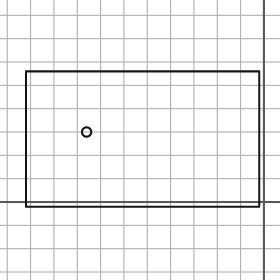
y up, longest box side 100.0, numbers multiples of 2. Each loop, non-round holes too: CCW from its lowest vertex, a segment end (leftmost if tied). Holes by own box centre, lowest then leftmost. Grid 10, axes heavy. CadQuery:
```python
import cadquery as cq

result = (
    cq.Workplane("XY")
    .moveTo(-102.0, -2.0)
    .lineTo(-2.0, -2.0)
    .lineTo(-2.0, 56.0)
    .lineTo(-102.0, 56.0)
    .close()
    .moveTo(-76.0, 30.0)
    .circle(2.0)
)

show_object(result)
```